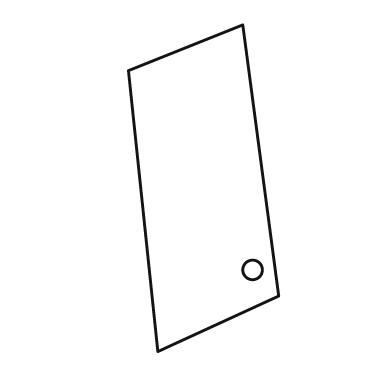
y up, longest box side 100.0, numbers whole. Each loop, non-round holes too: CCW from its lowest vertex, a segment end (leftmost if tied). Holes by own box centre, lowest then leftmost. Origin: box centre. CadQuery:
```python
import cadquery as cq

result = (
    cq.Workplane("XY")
    .moveTo(-14.0, -50.0)
    .lineTo(23.0, -33.0)
    .lineTo(12.0, 50.0)
    .lineTo(-23.0, 36.0)
    .close()
    .moveTo(15.0, -25.0)
    .circle(3.0)
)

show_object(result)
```